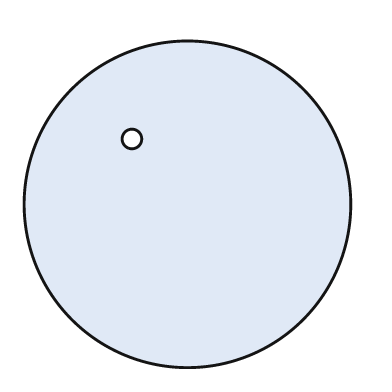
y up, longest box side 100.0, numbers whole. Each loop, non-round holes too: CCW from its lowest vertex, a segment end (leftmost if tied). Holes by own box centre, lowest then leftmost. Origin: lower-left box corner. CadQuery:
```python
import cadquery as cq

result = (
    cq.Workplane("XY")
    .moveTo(50.0, 50.0)
    .circle(50.0)
    .moveTo(33.0, 70.0)
    .circle(3.0)
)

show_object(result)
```